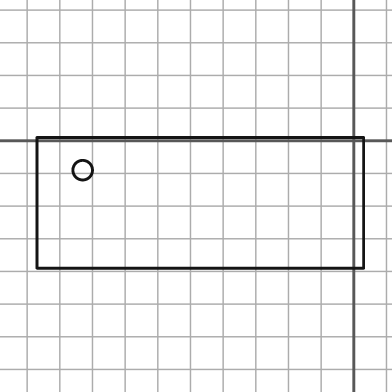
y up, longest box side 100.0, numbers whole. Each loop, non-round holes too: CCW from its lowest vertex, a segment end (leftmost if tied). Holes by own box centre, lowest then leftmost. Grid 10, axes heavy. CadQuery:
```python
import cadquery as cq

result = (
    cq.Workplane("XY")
    .moveTo(-97.0, -39.0)
    .lineTo(3.0, -39.0)
    .lineTo(3.0, 1.0)
    .lineTo(-97.0, 1.0)
    .close()
    .moveTo(-83.0, -9.0)
    .circle(3.0)
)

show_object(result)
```